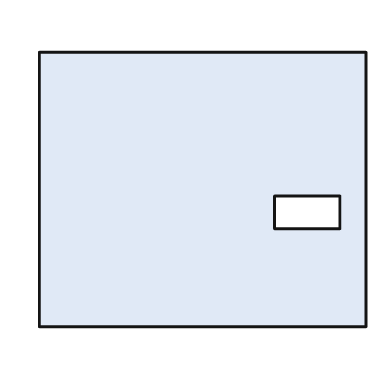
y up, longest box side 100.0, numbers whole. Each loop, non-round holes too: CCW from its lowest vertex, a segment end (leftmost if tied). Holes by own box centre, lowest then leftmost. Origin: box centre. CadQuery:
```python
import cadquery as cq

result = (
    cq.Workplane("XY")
    .moveTo(-50.0, -42.0)
    .lineTo(50.0, -42.0)
    .lineTo(50.0, 42.0)
    .lineTo(-50.0, 42.0)
    .close()
    .moveTo(22.0, -12.0)
    .lineTo(42.0, -12.0)
    .lineTo(42.0, -2.0)
    .lineTo(22.0, -2.0)
    .close()
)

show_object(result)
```